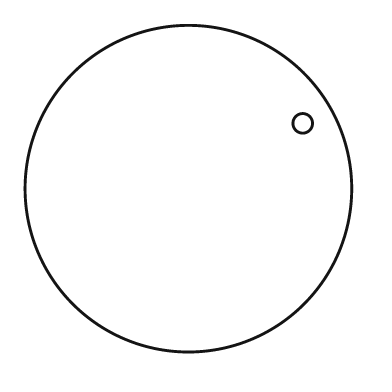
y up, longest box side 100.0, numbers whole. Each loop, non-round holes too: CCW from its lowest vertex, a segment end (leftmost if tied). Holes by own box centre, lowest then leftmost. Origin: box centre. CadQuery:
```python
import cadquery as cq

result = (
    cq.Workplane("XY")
    .moveTo(0.0, 0.0)
    .circle(50.0)
    .moveTo(35.0, 20.0)
    .circle(3.0)
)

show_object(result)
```